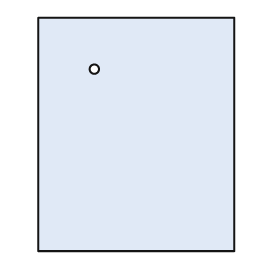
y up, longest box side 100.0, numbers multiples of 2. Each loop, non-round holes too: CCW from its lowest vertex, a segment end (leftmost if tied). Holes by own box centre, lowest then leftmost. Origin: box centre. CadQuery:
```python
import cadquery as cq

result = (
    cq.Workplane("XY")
    .moveTo(-42.0, -50.0)
    .lineTo(42.0, -50.0)
    .lineTo(42.0, 50.0)
    .lineTo(-42.0, 50.0)
    .close()
    .moveTo(-18.0, 28.0)
    .circle(2.0)
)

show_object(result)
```